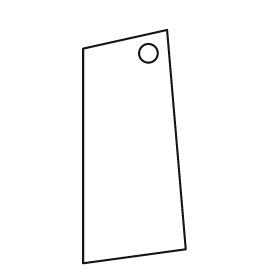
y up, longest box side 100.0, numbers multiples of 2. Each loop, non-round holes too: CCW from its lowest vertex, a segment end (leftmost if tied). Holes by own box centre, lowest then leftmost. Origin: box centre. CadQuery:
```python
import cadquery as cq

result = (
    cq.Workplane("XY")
    .moveTo(-22.0, -50.0)
    .lineTo(22.0, -44.0)
    .lineTo(14.0, 50.0)
    .lineTo(-22.0, 42.0)
    .close()
    .moveTo(6.0, 40.0)
    .circle(4.0)
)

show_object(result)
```